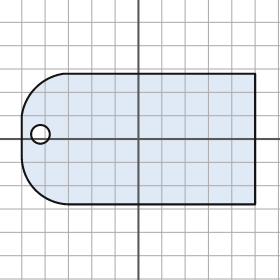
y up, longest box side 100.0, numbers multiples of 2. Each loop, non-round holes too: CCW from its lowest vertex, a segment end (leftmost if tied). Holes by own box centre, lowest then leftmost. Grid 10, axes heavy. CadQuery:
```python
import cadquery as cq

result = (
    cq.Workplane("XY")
    .moveTo(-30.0, -28.0)
    .lineTo(50.0, -28.0)
    .lineTo(50.0, 28.0)
    .lineTo(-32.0, 28.0)
    .threePointArc((-44.0, 22.0), (-50.0, 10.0))
    .lineTo(-50.0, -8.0)
    .threePointArc((-44.0, -22.0), (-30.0, -28.0))
    .close()
    .moveTo(-42.0, 2.0)
    .circle(4.0)
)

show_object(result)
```